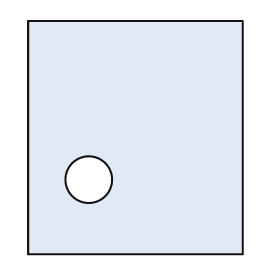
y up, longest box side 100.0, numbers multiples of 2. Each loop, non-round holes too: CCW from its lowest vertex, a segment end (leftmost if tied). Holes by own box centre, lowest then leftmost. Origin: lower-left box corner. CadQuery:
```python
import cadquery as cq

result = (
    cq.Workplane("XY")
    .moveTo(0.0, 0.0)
    .lineTo(92.0, 0.0)
    .lineTo(92.0, 100.0)
    .lineTo(0.0, 100.0)
    .close()
    .moveTo(26.0, 32.0)
    .circle(10.0)
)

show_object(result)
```